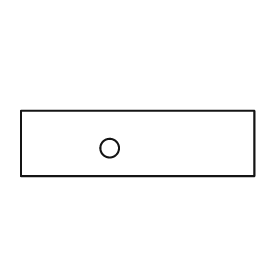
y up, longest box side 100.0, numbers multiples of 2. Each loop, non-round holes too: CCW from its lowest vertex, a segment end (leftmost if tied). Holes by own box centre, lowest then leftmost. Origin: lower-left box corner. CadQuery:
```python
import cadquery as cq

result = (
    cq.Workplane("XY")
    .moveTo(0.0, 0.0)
    .lineTo(100.0, 0.0)
    .lineTo(100.0, 28.0)
    .lineTo(0.0, 28.0)
    .close()
    .moveTo(38.0, 12.0)
    .circle(4.0)
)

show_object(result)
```